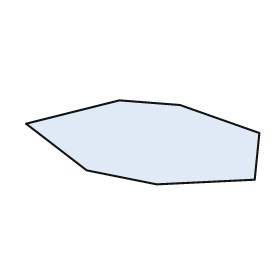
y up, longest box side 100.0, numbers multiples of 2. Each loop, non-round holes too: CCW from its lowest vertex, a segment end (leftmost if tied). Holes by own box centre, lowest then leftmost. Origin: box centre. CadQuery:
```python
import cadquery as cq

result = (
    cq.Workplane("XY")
    .moveTo(6.0, -18.0)
    .lineTo(48.0, -16.0)
    .lineTo(50.0, 4.0)
    .lineTo(16.0, 16.0)
    .lineTo(-10.0, 18.0)
    .lineTo(-50.0, 8.0)
    .lineTo(-24.0, -12.0)
    .close()
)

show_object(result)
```